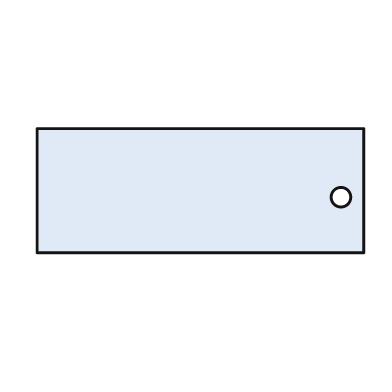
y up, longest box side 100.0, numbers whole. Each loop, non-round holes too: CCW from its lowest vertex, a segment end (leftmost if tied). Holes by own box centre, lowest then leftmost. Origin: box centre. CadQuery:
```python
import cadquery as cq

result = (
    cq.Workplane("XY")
    .moveTo(-50.0, -19.0)
    .lineTo(50.0, -19.0)
    .lineTo(50.0, 19.0)
    .lineTo(-50.0, 19.0)
    .close()
    .moveTo(43.0, -2.0)
    .circle(3.0)
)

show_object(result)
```